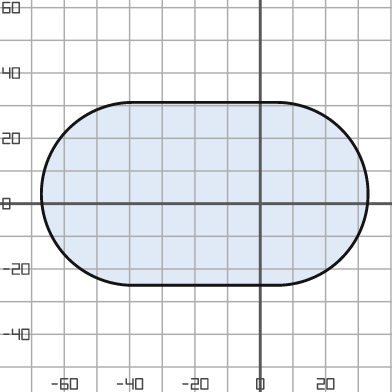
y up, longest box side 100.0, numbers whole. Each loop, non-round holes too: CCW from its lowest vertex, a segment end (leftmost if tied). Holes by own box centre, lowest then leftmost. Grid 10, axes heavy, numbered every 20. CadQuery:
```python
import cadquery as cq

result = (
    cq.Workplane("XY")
    .moveTo(-39.0, -25.0)
    .lineTo(5.0, -25.0)
    .threePointArc((33.0, 3.0), (5.0, 31.0))
    .lineTo(-39.0, 31.0)
    .threePointArc((-67.0, 3.0), (-39.0, -25.0))
    .close()
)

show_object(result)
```